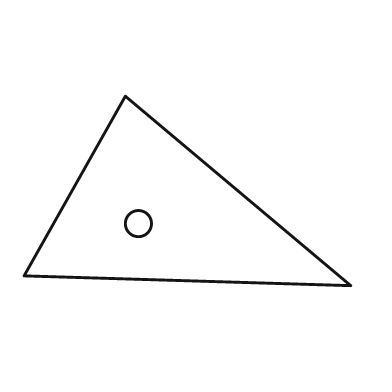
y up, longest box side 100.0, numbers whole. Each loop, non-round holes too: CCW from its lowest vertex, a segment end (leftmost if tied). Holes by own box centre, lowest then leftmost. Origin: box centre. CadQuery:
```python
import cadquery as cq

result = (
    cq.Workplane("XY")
    .moveTo(50.0, -29.0)
    .lineTo(-19.0, 29.0)
    .lineTo(-50.0, -26.0)
    .close()
    .moveTo(-15.0, -10.0)
    .circle(4.0)
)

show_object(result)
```